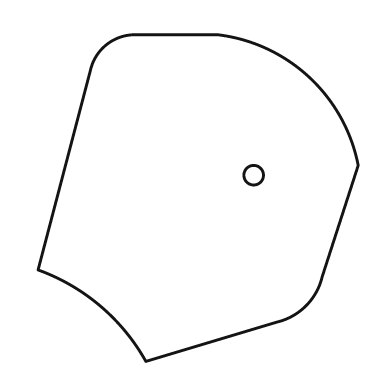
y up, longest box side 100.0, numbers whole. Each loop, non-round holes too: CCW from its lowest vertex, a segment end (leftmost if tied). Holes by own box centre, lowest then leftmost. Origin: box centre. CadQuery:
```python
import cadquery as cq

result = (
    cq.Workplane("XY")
    .moveTo(-16.0, -50.0)
    .lineTo(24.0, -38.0)
    .threePointArc((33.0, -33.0), (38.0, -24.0))
    .lineTo(49.0, 10.0)
    .threePointArc((34.0, 37.0), (6.0, 50.0))
    .lineTo(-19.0, 50.0)
    .threePointArc((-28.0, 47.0), (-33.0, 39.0))
    .lineTo(-49.0, -22.0)
    .threePointArc((-30.0, -33.0), (-16.0, -50.0))
    .close()
    .moveTo(17.0, 7.0)
    .circle(3.0)
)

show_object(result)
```